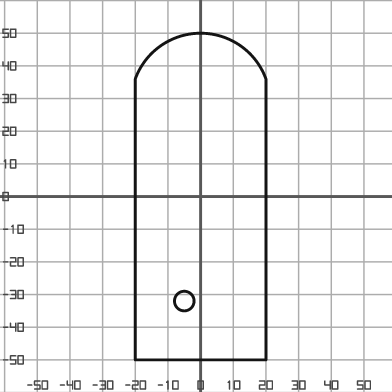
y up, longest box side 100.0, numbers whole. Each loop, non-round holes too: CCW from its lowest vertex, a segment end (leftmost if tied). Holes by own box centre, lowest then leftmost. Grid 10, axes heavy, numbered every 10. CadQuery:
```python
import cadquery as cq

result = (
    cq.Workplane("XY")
    .moveTo(-20.0, -50.0)
    .lineTo(20.0, -50.0)
    .lineTo(20.0, 36.0)
    .threePointArc((0.0, 50.0), (-20.0, 36.0))
    .close()
    .moveTo(-5.0, -32.0)
    .circle(3.0)
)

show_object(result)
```